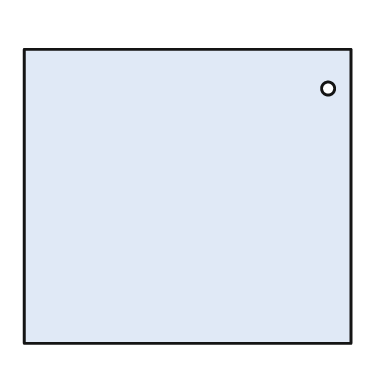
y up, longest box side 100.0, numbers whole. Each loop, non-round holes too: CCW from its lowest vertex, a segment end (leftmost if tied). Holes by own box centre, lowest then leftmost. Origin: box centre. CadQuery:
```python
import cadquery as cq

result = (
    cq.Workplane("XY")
    .moveTo(-50.0, -45.0)
    .lineTo(50.0, -45.0)
    .lineTo(50.0, 45.0)
    .lineTo(-50.0, 45.0)
    .close()
    .moveTo(43.0, 33.0)
    .circle(2.0)
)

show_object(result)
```